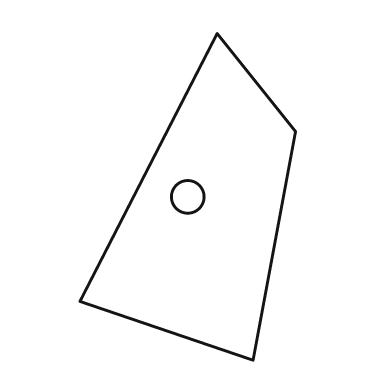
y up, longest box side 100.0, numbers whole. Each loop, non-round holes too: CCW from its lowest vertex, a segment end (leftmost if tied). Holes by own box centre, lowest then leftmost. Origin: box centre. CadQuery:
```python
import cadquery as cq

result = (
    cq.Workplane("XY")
    .moveTo(20.0, -50.0)
    .lineTo(33.0, 20.0)
    .lineTo(9.0, 50.0)
    .lineTo(-33.0, -32.0)
    .close()
    .moveTo(0.0, 0.0)
    .circle(5.0)
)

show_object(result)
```